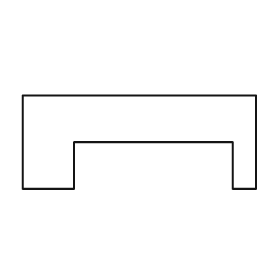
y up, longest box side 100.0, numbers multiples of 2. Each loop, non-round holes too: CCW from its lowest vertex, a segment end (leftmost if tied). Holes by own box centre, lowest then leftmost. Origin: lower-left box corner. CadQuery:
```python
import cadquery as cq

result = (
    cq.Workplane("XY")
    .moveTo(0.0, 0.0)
    .lineTo(22.0, 0.0)
    .lineTo(22.0, 20.0)
    .lineTo(90.0, 20.0)
    .lineTo(90.0, 0.0)
    .lineTo(100.0, 0.0)
    .lineTo(100.0, 40.0)
    .lineTo(0.0, 40.0)
    .close()
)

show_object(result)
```